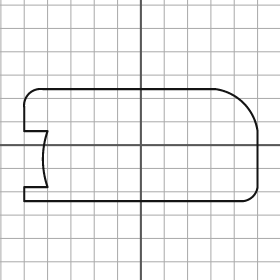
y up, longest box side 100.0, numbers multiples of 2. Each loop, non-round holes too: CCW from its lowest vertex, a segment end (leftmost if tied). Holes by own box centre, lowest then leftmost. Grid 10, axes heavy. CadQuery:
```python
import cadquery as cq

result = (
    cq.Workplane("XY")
    .moveTo(-50.0, -24.0)
    .lineTo(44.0, -24.0)
    .threePointArc((48.0, -22.0), (50.0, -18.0))
    .lineTo(50.0, 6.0)
    .threePointArc((44.0, 18.0), (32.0, 24.0))
    .lineTo(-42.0, 24.0)
    .threePointArc((-48.0, 22.0), (-50.0, 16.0))
    .lineTo(-50.0, 6.0)
    .lineTo(-40.0, 6.0)
    .threePointArc((-42.0, -6.0), (-40.0, -18.0))
    .lineTo(-50.0, -18.0)
    .close()
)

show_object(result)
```